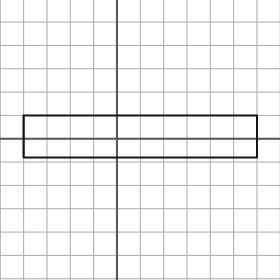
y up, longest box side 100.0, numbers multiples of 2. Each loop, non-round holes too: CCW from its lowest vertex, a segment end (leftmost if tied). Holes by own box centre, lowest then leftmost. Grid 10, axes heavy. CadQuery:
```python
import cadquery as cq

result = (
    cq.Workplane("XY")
    .moveTo(-40.0, -8.0)
    .lineTo(60.0, -8.0)
    .lineTo(60.0, 10.0)
    .lineTo(-40.0, 10.0)
    .close()
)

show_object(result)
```